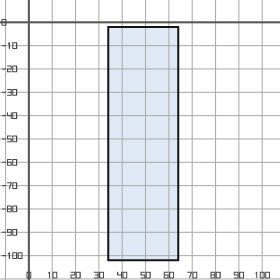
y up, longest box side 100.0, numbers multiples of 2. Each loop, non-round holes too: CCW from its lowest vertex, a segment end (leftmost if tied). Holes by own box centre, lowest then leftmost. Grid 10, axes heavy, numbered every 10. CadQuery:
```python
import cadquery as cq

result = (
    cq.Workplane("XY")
    .moveTo(34.0, -102.0)
    .lineTo(64.0, -102.0)
    .lineTo(64.0, -2.0)
    .lineTo(34.0, -2.0)
    .close()
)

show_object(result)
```